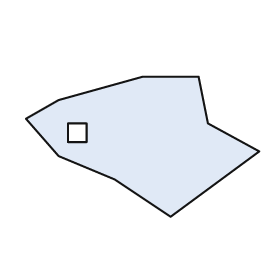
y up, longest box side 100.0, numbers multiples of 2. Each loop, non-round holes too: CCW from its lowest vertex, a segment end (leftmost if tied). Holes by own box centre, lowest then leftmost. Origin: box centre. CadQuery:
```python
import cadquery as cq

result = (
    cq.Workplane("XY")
    .moveTo(12.0, -30.0)
    .lineTo(50.0, -2.0)
    .lineTo(28.0, 10.0)
    .lineTo(24.0, 30.0)
    .lineTo(0.0, 30.0)
    .lineTo(-36.0, 20.0)
    .lineTo(-50.0, 12.0)
    .lineTo(-36.0, -4.0)
    .lineTo(-12.0, -14.0)
    .close()
    .moveTo(-32.0, 2.0)
    .lineTo(-24.0, 2.0)
    .lineTo(-24.0, 10.0)
    .lineTo(-32.0, 10.0)
    .close()
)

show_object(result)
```